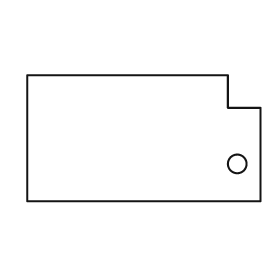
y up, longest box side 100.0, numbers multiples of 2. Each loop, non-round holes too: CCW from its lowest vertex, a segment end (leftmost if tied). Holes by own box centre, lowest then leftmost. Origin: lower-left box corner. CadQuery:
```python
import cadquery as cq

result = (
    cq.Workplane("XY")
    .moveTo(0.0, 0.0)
    .lineTo(100.0, 0.0)
    .lineTo(100.0, 40.0)
    .lineTo(86.0, 40.0)
    .lineTo(86.0, 54.0)
    .lineTo(0.0, 54.0)
    .close()
    .moveTo(90.0, 16.0)
    .circle(4.0)
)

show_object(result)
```